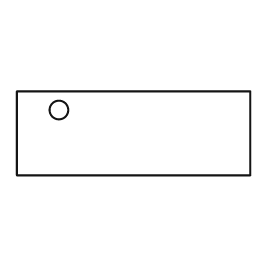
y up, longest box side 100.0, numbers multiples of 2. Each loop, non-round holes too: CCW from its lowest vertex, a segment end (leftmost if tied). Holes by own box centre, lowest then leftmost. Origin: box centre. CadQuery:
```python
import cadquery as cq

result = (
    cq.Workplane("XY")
    .moveTo(-50.0, -18.0)
    .lineTo(50.0, -18.0)
    .lineTo(50.0, 18.0)
    .lineTo(-50.0, 18.0)
    .close()
    .moveTo(-32.0, 10.0)
    .circle(4.0)
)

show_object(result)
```